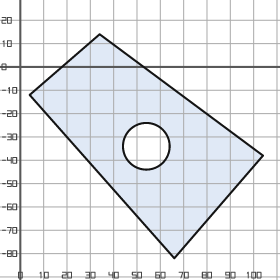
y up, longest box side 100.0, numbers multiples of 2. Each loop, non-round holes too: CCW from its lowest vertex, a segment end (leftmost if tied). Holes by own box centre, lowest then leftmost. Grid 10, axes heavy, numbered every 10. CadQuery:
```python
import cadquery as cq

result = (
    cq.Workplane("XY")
    .moveTo(66.0, -82.0)
    .lineTo(104.0, -38.0)
    .lineTo(34.0, 14.0)
    .lineTo(4.0, -12.0)
    .close()
    .moveTo(54.0, -34.0)
    .circle(10.0)
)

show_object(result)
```